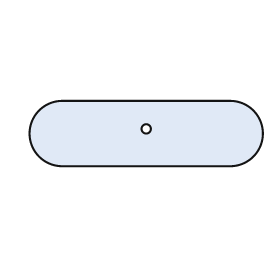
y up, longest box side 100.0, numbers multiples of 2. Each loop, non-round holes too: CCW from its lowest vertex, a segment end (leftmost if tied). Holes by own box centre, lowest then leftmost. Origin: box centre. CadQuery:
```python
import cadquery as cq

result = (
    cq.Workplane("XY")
    .moveTo(-36.0, -14.0)
    .lineTo(36.0, -14.0)
    .threePointArc((50.0, 0.0), (36.0, 14.0))
    .lineTo(-36.0, 14.0)
    .threePointArc((-50.0, 0.0), (-36.0, -14.0))
    .close()
    .moveTo(0.0, 2.0)
    .circle(2.0)
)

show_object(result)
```